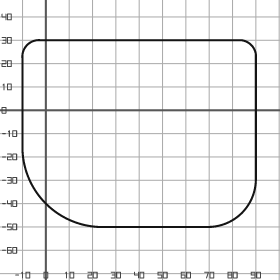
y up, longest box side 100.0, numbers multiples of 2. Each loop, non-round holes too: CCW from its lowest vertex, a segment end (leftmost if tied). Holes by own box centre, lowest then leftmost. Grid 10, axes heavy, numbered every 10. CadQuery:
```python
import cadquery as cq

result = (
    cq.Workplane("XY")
    .moveTo(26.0, -50.0)
    .lineTo(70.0, -50.0)
    .threePointArc((84.0, -44.0), (90.0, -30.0))
    .lineTo(90.0, 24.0)
    .threePointArc((88.0, 28.0), (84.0, 30.0))
    .lineTo(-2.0, 30.0)
    .threePointArc((-8.0, 28.0), (-10.0, 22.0))
    .lineTo(-10.0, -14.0)
    .threePointArc((0.0, -40.0), (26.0, -50.0))
    .close()
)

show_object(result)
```